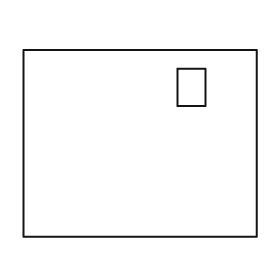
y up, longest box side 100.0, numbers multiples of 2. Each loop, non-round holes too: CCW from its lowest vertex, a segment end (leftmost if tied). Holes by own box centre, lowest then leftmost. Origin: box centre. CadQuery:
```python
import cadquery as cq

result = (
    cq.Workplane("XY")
    .moveTo(-50.0, -40.0)
    .lineTo(50.0, -40.0)
    .lineTo(50.0, 40.0)
    .lineTo(-50.0, 40.0)
    .close()
    .moveTo(16.0, 16.0)
    .lineTo(28.0, 16.0)
    .lineTo(28.0, 32.0)
    .lineTo(16.0, 32.0)
    .close()
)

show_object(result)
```